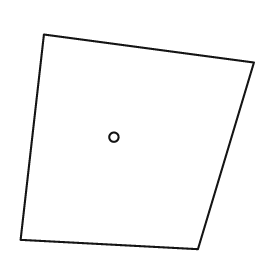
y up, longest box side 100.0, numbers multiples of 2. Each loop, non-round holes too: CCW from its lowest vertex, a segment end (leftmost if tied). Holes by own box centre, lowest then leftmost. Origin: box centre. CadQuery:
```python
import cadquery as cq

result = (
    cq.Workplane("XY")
    .moveTo(26.0, -46.0)
    .lineTo(50.0, 34.0)
    .lineTo(-40.0, 46.0)
    .lineTo(-50.0, -42.0)
    .close()
    .moveTo(-10.0, 2.0)
    .circle(2.0)
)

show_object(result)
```